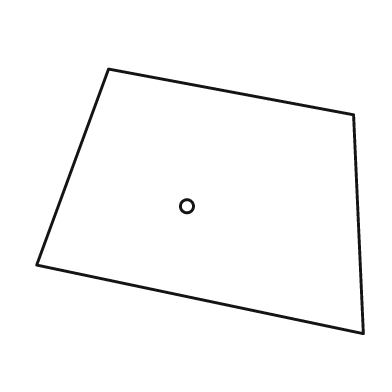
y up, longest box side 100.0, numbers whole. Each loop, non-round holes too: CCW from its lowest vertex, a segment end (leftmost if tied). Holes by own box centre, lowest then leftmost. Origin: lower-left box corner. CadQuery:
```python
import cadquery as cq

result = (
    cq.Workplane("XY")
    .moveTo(100.0, 0.0)
    .lineTo(97.0, 67.0)
    .lineTo(22.0, 81.0)
    .lineTo(0.0, 21.0)
    .close()
    .moveTo(46.0, 39.0)
    .circle(2.0)
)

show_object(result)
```